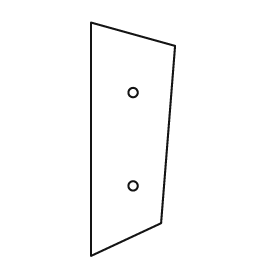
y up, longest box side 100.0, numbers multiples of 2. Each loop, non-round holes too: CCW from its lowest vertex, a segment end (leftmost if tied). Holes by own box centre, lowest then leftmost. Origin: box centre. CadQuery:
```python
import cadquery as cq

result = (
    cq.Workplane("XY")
    .moveTo(-18.0, -50.0)
    .lineTo(12.0, -36.0)
    .lineTo(18.0, 40.0)
    .lineTo(-18.0, 50.0)
    .close()
    .moveTo(0.0, -20.0)
    .circle(2.0)
    .moveTo(0.0, 20.0)
    .circle(2.0)
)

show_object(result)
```